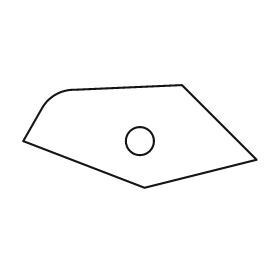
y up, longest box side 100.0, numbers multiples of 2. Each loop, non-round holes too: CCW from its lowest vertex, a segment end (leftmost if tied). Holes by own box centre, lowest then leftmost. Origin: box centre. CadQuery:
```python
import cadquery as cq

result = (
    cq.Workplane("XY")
    .moveTo(2.0, -22.0)
    .lineTo(50.0, -10.0)
    .lineTo(18.0, 22.0)
    .lineTo(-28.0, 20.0)
    .threePointArc((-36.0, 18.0), (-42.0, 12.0))
    .lineTo(-50.0, -2.0)
    .close()
    .moveTo(0.0, -2.0)
    .circle(6.0)
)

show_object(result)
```